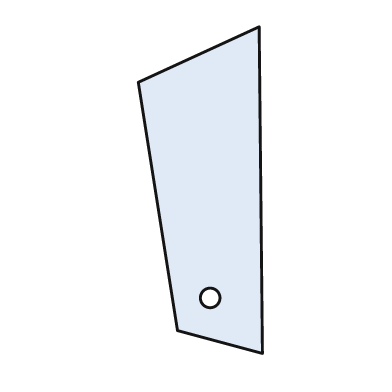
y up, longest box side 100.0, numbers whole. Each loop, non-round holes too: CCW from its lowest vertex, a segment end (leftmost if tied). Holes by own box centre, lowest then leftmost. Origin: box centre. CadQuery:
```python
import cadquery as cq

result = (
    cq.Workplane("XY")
    .moveTo(19.0, -50.0)
    .lineTo(18.0, 50.0)
    .lineTo(-19.0, 33.0)
    .lineTo(-7.0, -43.0)
    .close()
    .moveTo(3.0, -33.0)
    .circle(3.0)
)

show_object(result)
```